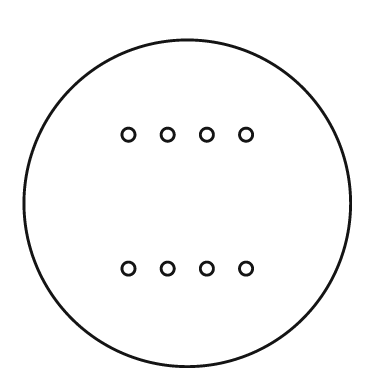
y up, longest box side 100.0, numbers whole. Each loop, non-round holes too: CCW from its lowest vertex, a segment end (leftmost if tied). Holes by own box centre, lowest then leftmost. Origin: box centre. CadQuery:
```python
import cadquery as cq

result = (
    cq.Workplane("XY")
    .moveTo(0.0, 0.0)
    .circle(50.0)
    .moveTo(-18.0, -20.0)
    .circle(2.0)
    .moveTo(-6.0, -20.0)
    .circle(2.0)
    .moveTo(6.0, -20.0)
    .circle(2.0)
    .moveTo(18.0, -20.0)
    .circle(2.0)
    .moveTo(-18.0, 21.0)
    .circle(2.0)
    .moveTo(-6.0, 21.0)
    .circle(2.0)
    .moveTo(6.0, 21.0)
    .circle(2.0)
    .moveTo(18.0, 21.0)
    .circle(2.0)
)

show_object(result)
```